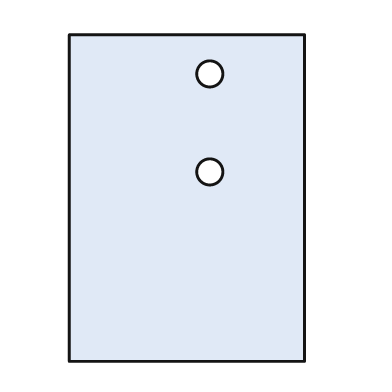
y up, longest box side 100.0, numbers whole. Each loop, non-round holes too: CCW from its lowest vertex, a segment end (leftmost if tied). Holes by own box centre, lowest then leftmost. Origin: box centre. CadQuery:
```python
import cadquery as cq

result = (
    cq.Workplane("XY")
    .moveTo(-36.0, -50.0)
    .lineTo(36.0, -50.0)
    .lineTo(36.0, 50.0)
    .lineTo(-36.0, 50.0)
    .close()
    .moveTo(7.0, 8.0)
    .circle(4.0)
    .moveTo(7.0, 38.0)
    .circle(4.0)
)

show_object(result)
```